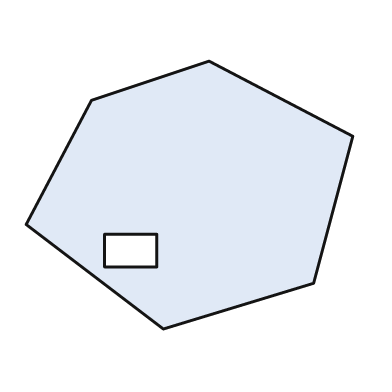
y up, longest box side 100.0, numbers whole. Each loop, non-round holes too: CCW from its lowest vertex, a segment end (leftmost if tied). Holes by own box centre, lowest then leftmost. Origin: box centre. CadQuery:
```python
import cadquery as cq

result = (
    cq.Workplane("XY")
    .moveTo(-8.0, -41.0)
    .lineTo(38.0, -27.0)
    .lineTo(50.0, 18.0)
    .lineTo(6.0, 41.0)
    .lineTo(-30.0, 29.0)
    .lineTo(-50.0, -9.0)
    .close()
    .moveTo(-26.0, -22.0)
    .lineTo(-10.0, -22.0)
    .lineTo(-10.0, -12.0)
    .lineTo(-26.0, -12.0)
    .close()
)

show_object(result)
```